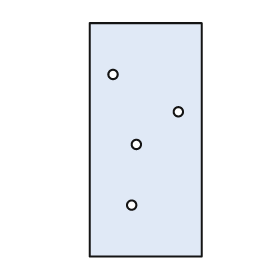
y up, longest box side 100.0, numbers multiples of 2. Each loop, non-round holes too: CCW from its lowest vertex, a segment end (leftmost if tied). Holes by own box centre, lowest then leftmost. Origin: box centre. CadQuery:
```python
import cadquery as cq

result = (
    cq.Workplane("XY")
    .moveTo(-24.0, -50.0)
    .lineTo(24.0, -50.0)
    .lineTo(24.0, 50.0)
    .lineTo(-24.0, 50.0)
    .close()
    .moveTo(-6.0, -28.0)
    .circle(2.0)
    .moveTo(-4.0, -2.0)
    .circle(2.0)
    .moveTo(14.0, 12.0)
    .circle(2.0)
    .moveTo(-14.0, 28.0)
    .circle(2.0)
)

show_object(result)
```